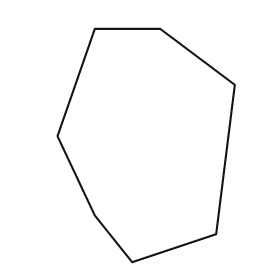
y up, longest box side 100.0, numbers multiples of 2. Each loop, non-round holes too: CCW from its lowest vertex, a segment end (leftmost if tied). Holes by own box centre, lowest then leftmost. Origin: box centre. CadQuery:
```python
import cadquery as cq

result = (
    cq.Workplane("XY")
    .moveTo(-6.0, -50.0)
    .lineTo(30.0, -38.0)
    .lineTo(38.0, 26.0)
    .lineTo(6.0, 50.0)
    .lineTo(-22.0, 50.0)
    .lineTo(-38.0, 4.0)
    .lineTo(-22.0, -30.0)
    .close()
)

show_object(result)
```